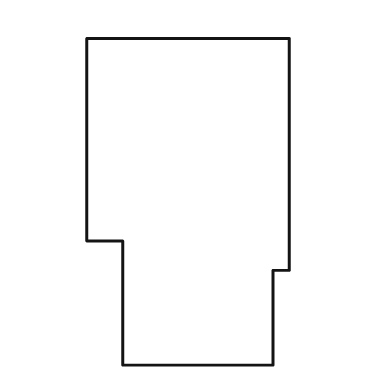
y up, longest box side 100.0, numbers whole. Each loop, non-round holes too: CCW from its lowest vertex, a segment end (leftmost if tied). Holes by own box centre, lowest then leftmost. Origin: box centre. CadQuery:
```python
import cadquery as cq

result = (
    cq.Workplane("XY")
    .moveTo(-20.0, -50.0)
    .lineTo(26.0, -50.0)
    .lineTo(26.0, -21.0)
    .lineTo(31.0, -21.0)
    .lineTo(31.0, 50.0)
    .lineTo(-31.0, 50.0)
    .lineTo(-31.0, -12.0)
    .lineTo(-20.0, -12.0)
    .close()
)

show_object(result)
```